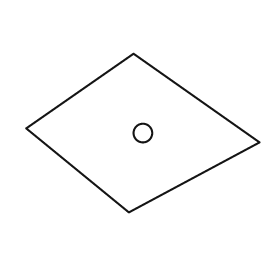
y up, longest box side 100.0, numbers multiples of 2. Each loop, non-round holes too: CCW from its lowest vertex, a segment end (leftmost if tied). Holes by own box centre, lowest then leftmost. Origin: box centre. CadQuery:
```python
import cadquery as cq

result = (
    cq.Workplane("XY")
    .moveTo(-6.0, -34.0)
    .lineTo(50.0, -4.0)
    .lineTo(-4.0, 34.0)
    .lineTo(-50.0, 2.0)
    .close()
    .moveTo(0.0, 0.0)
    .circle(4.0)
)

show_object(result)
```